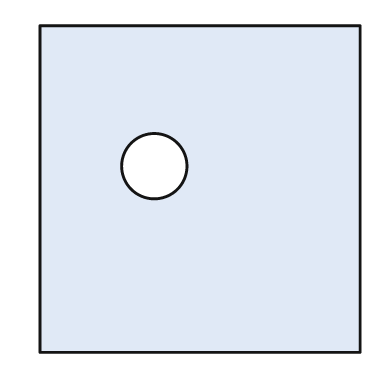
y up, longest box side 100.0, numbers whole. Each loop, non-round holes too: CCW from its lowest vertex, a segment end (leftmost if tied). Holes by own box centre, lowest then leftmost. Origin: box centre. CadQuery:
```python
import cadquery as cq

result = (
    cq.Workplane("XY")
    .moveTo(-49.0, -50.0)
    .lineTo(49.0, -50.0)
    .lineTo(49.0, 50.0)
    .lineTo(-49.0, 50.0)
    .close()
    .moveTo(-14.0, 7.0)
    .circle(10.0)
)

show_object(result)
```